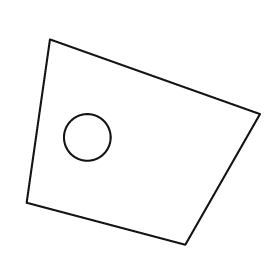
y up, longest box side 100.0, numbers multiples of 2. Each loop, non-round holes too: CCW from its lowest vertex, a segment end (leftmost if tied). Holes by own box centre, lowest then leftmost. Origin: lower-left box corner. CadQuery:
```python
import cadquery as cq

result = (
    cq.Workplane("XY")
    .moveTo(68.0, 0.0)
    .lineTo(100.0, 56.0)
    .lineTo(10.0, 88.0)
    .lineTo(0.0, 18.0)
    .close()
    .moveTo(26.0, 46.0)
    .circle(10.0)
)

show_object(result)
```